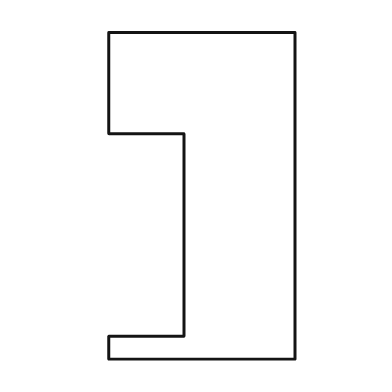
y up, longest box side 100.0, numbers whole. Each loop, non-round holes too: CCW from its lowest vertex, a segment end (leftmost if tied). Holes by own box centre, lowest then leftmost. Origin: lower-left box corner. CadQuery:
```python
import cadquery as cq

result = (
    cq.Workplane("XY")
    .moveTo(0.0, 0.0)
    .lineTo(57.0, 0.0)
    .lineTo(57.0, 100.0)
    .lineTo(0.0, 100.0)
    .lineTo(0.0, 69.0)
    .lineTo(23.0, 69.0)
    .lineTo(23.0, 7.0)
    .lineTo(0.0, 7.0)
    .close()
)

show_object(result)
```